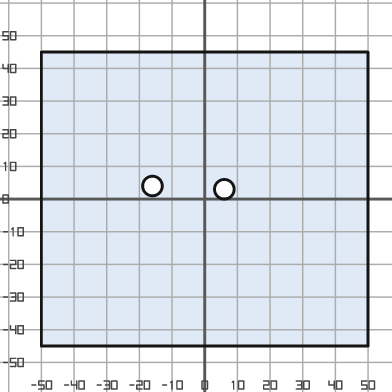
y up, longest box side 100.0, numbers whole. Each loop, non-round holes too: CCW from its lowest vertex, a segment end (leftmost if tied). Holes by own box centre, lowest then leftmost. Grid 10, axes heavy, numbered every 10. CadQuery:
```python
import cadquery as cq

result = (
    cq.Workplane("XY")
    .moveTo(-50.0, -45.0)
    .lineTo(50.0, -45.0)
    .lineTo(50.0, 45.0)
    .lineTo(-50.0, 45.0)
    .close()
    .moveTo(6.0, 3.0)
    .circle(3.0)
    .moveTo(-16.0, 4.0)
    .circle(3.0)
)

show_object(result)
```